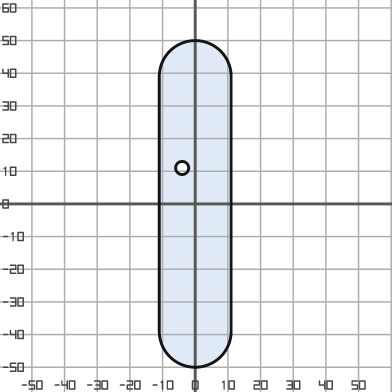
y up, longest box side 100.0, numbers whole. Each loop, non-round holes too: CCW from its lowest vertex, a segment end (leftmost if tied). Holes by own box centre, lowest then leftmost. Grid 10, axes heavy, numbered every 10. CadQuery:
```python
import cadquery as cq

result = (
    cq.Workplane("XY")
    .moveTo(-11.0, -39.0)
    .threePointArc((0.0, -50.0), (11.0, -39.0))
    .lineTo(11.0, 39.0)
    .threePointArc((0.0, 50.0), (-11.0, 39.0))
    .close()
    .moveTo(-4.0, 11.0)
    .circle(2.0)
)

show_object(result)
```